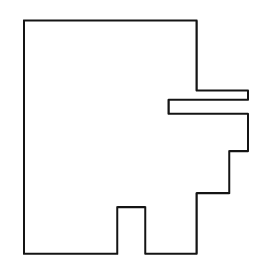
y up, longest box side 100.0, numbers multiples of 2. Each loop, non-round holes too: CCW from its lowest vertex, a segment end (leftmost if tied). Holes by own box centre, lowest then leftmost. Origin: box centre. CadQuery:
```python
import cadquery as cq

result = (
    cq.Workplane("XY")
    .moveTo(-48.0, -50.0)
    .lineTo(-8.0, -50.0)
    .lineTo(-8.0, -30.0)
    .lineTo(4.0, -30.0)
    .lineTo(4.0, -50.0)
    .lineTo(26.0, -50.0)
    .lineTo(26.0, -24.0)
    .lineTo(40.0, -24.0)
    .lineTo(40.0, -6.0)
    .lineTo(48.0, -6.0)
    .lineTo(48.0, 10.0)
    .lineTo(14.0, 10.0)
    .lineTo(14.0, 16.0)
    .lineTo(48.0, 16.0)
    .lineTo(48.0, 20.0)
    .lineTo(26.0, 20.0)
    .lineTo(26.0, 50.0)
    .lineTo(-48.0, 50.0)
    .close()
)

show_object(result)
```